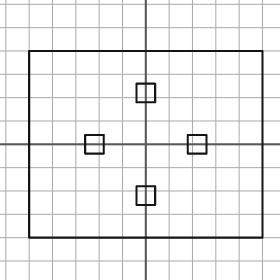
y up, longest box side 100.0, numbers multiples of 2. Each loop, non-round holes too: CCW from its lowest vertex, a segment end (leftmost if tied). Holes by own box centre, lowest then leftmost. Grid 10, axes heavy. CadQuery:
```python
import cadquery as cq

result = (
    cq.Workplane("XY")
    .moveTo(-50.0, -40.0)
    .lineTo(50.0, -40.0)
    .lineTo(50.0, 40.0)
    .lineTo(-50.0, 40.0)
    .close()
    .moveTo(-4.0, -26.0)
    .lineTo(4.0, -26.0)
    .lineTo(4.0, -18.0)
    .lineTo(-4.0, -18.0)
    .close()
    .moveTo(-26.0, -4.0)
    .lineTo(-18.0, -4.0)
    .lineTo(-18.0, 4.0)
    .lineTo(-26.0, 4.0)
    .close()
    .moveTo(18.0, -4.0)
    .lineTo(26.0, -4.0)
    .lineTo(26.0, 4.0)
    .lineTo(18.0, 4.0)
    .close()
    .moveTo(-4.0, 18.0)
    .lineTo(4.0, 18.0)
    .lineTo(4.0, 26.0)
    .lineTo(-4.0, 26.0)
    .close()
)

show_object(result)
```